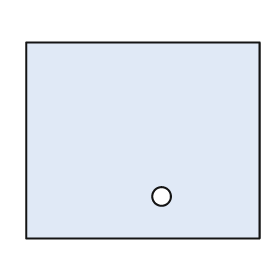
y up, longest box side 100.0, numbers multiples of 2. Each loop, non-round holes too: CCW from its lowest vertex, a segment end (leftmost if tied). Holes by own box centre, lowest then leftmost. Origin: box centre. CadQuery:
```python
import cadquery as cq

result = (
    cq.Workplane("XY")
    .moveTo(-50.0, -42.0)
    .lineTo(50.0, -42.0)
    .lineTo(50.0, 42.0)
    .lineTo(-50.0, 42.0)
    .close()
    .moveTo(8.0, -24.0)
    .circle(4.0)
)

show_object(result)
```